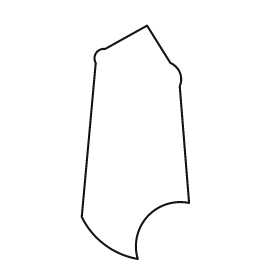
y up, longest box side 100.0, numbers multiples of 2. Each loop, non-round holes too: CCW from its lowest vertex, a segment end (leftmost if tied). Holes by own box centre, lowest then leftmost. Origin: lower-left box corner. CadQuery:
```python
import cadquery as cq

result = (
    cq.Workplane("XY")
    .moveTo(24.0, 0.0)
    .threePointArc((28.0, 18.0), (46.0, 24.0))
    .lineTo(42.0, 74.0)
    .threePointArc((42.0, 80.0), (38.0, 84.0))
    .lineTo(28.0, 100.0)
    .lineTo(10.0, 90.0)
    .threePointArc((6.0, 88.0), (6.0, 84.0))
    .lineTo(0.0, 18.0)
    .threePointArc((10.0, 6.0), (24.0, 0.0))
    .close()
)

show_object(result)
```